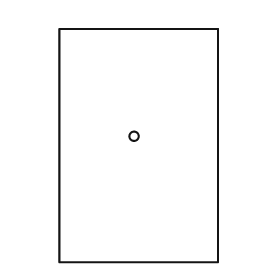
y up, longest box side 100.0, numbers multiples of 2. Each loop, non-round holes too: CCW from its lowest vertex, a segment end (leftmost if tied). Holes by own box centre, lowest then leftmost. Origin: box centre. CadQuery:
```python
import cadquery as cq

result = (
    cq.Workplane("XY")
    .moveTo(-34.0, -50.0)
    .lineTo(34.0, -50.0)
    .lineTo(34.0, 50.0)
    .lineTo(-34.0, 50.0)
    .close()
    .moveTo(-2.0, 4.0)
    .circle(2.0)
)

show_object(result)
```